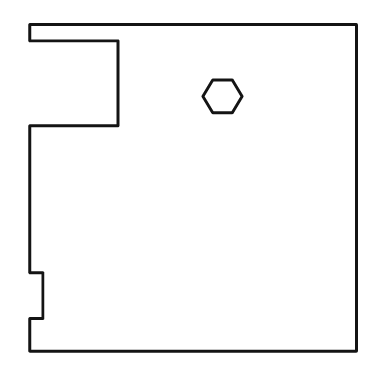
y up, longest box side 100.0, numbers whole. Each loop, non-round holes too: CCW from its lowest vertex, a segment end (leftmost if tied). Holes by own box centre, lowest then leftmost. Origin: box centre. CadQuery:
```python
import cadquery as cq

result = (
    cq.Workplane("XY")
    .moveTo(-50.0, -50.0)
    .lineTo(50.0, -50.0)
    .lineTo(50.0, 50.0)
    .lineTo(-50.0, 50.0)
    .lineTo(-50.0, 45.0)
    .lineTo(-23.0, 45.0)
    .lineTo(-23.0, 19.0)
    .lineTo(-50.0, 19.0)
    .lineTo(-50.0, -26.0)
    .lineTo(-46.0, -26.0)
    .lineTo(-46.0, -40.0)
    .lineTo(-50.0, -40.0)
    .close()
    .moveTo(6.0, 23.0)
    .lineTo(12.0, 23.0)
    .lineTo(15.0, 28.0)
    .lineTo(12.0, 33.0)
    .lineTo(6.0, 33.0)
    .lineTo(3.0, 28.0)
    .close()
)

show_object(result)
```